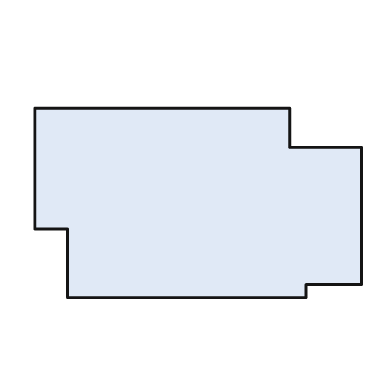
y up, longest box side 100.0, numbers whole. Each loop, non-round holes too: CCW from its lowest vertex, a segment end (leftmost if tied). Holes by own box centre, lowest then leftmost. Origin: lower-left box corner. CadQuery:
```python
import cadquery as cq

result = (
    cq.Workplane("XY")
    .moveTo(10.0, 0.0)
    .lineTo(83.0, 0.0)
    .lineTo(83.0, 4.0)
    .lineTo(100.0, 4.0)
    .lineTo(100.0, 46.0)
    .lineTo(78.0, 46.0)
    .lineTo(78.0, 58.0)
    .lineTo(0.0, 58.0)
    .lineTo(0.0, 21.0)
    .lineTo(10.0, 21.0)
    .close()
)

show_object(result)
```